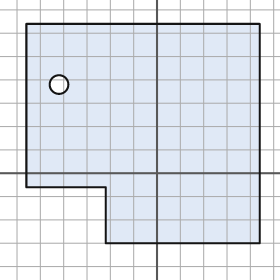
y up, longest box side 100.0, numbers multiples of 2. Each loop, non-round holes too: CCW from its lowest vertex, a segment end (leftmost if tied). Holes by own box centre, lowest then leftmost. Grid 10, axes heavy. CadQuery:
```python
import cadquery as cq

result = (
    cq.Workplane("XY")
    .moveTo(-22.0, -30.0)
    .lineTo(44.0, -30.0)
    .lineTo(44.0, 64.0)
    .lineTo(-56.0, 64.0)
    .lineTo(-56.0, -6.0)
    .lineTo(-22.0, -6.0)
    .close()
    .moveTo(-42.0, 38.0)
    .circle(4.0)
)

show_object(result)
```